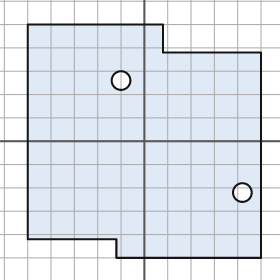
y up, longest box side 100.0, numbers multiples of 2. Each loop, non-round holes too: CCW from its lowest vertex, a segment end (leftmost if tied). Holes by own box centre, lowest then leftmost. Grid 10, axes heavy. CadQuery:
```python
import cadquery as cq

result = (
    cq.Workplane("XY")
    .moveTo(-12.0, -50.0)
    .lineTo(50.0, -50.0)
    .lineTo(50.0, 38.0)
    .lineTo(8.0, 38.0)
    .lineTo(8.0, 50.0)
    .lineTo(-50.0, 50.0)
    .lineTo(-50.0, -42.0)
    .lineTo(-12.0, -42.0)
    .close()
    .moveTo(42.0, -22.0)
    .circle(4.0)
    .moveTo(-10.0, 26.0)
    .circle(4.0)
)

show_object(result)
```